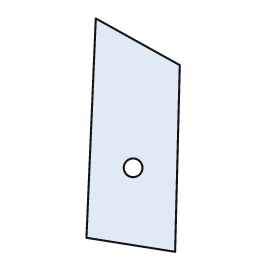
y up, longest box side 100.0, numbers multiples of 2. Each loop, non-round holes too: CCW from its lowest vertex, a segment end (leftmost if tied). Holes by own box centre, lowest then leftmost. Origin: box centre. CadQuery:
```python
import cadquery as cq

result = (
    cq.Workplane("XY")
    .moveTo(18.0, -50.0)
    .lineTo(20.0, 30.0)
    .lineTo(-16.0, 50.0)
    .lineTo(-20.0, -44.0)
    .close()
    .moveTo(0.0, -14.0)
    .circle(4.0)
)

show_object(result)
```